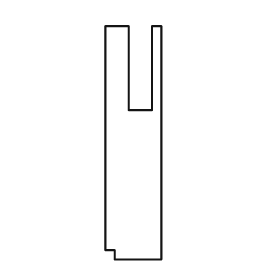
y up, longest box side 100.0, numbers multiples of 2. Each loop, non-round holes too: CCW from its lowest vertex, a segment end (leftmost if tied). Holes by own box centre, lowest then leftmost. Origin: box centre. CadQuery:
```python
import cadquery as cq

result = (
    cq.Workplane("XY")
    .moveTo(-8.0, -50.0)
    .lineTo(12.0, -50.0)
    .lineTo(12.0, 50.0)
    .lineTo(8.0, 50.0)
    .lineTo(8.0, 14.0)
    .lineTo(-2.0, 14.0)
    .lineTo(-2.0, 50.0)
    .lineTo(-12.0, 50.0)
    .lineTo(-12.0, -46.0)
    .lineTo(-8.0, -46.0)
    .close()
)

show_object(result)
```